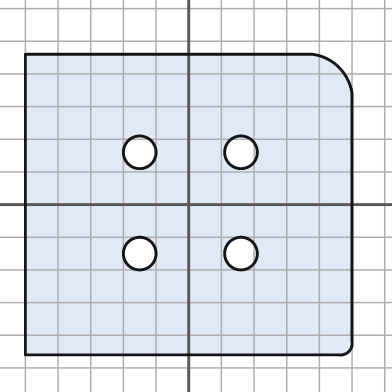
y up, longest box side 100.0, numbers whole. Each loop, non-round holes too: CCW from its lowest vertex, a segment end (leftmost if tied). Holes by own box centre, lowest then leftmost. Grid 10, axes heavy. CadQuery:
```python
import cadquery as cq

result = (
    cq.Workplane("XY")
    .moveTo(-50.0, -46.0)
    .lineTo(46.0, -46.0)
    .threePointArc((49.0, -45.0), (50.0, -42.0))
    .lineTo(50.0, 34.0)
    .threePointArc((46.0, 42.0), (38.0, 46.0))
    .lineTo(-50.0, 46.0)
    .close()
    .moveTo(-15.0, -15.0)
    .circle(5.0)
    .moveTo(16.0, -15.0)
    .circle(5.0)
    .moveTo(-15.0, 16.0)
    .circle(5.0)
    .moveTo(16.0, 16.0)
    .circle(5.0)
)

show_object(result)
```